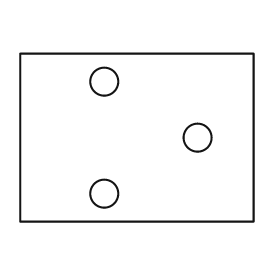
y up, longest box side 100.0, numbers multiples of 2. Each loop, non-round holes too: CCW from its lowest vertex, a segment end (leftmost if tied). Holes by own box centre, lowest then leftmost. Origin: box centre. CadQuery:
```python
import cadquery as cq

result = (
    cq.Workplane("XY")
    .moveTo(-50.0, -36.0)
    .lineTo(50.0, -36.0)
    .lineTo(50.0, 36.0)
    .lineTo(-50.0, 36.0)
    .close()
    .moveTo(-14.0, -24.0)
    .circle(6.0)
    .moveTo(26.0, 0.0)
    .circle(6.0)
    .moveTo(-14.0, 24.0)
    .circle(6.0)
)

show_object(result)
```